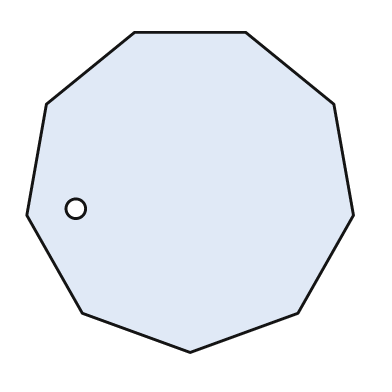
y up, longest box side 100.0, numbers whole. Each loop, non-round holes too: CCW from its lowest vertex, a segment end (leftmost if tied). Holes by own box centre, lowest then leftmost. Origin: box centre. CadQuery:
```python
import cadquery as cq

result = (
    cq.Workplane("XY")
    .moveTo(0.0, -49.0)
    .lineTo(33.0, -37.0)
    .lineTo(50.0, -7.0)
    .lineTo(44.0, 27.0)
    .lineTo(17.0, 49.0)
    .lineTo(-17.0, 49.0)
    .lineTo(-44.0, 27.0)
    .lineTo(-50.0, -7.0)
    .lineTo(-33.0, -37.0)
    .close()
    .moveTo(-35.0, -5.0)
    .circle(3.0)
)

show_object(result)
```